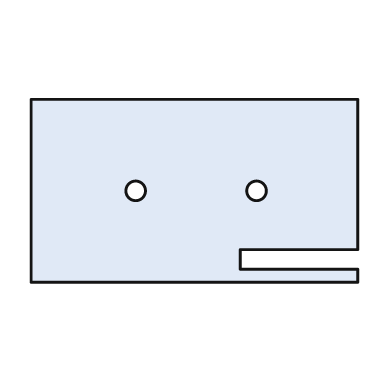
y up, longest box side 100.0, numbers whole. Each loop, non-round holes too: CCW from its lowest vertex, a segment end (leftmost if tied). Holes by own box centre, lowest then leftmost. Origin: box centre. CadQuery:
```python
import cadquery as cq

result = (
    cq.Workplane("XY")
    .moveTo(-50.0, -28.0)
    .lineTo(50.0, -28.0)
    .lineTo(50.0, -24.0)
    .lineTo(14.0, -24.0)
    .lineTo(14.0, -18.0)
    .lineTo(50.0, -18.0)
    .lineTo(50.0, 28.0)
    .lineTo(-50.0, 28.0)
    .close()
    .moveTo(-18.0, 0.0)
    .circle(3.0)
    .moveTo(19.0, 0.0)
    .circle(3.0)
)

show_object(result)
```